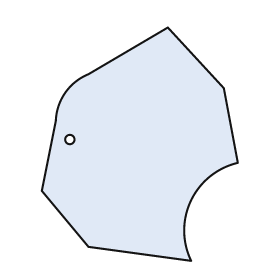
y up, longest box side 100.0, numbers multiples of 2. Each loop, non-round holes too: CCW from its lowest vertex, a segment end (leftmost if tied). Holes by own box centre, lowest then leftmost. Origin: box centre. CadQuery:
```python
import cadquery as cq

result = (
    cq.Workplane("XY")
    .moveTo(22.0, -50.0)
    .threePointArc((22.0, -24.0), (42.0, -8.0))
    .lineTo(36.0, 24.0)
    .lineTo(12.0, 50.0)
    .lineTo(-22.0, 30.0)
    .threePointArc((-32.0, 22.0), (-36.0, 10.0))
    .lineTo(-42.0, -20.0)
    .lineTo(-22.0, -44.0)
    .close()
    .moveTo(-30.0, 2.0)
    .circle(2.0)
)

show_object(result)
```